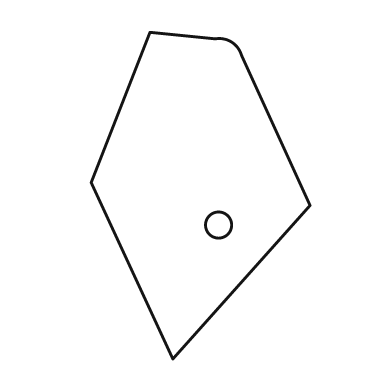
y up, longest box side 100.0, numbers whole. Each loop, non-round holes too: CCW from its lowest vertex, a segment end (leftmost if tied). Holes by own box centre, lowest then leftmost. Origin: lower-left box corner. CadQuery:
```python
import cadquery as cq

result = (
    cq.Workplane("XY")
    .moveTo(25.0, 0.0)
    .lineTo(67.0, 47.0)
    .lineTo(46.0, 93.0)
    .threePointArc((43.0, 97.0), (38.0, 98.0))
    .lineTo(18.0, 100.0)
    .lineTo(0.0, 54.0)
    .close()
    .moveTo(39.0, 41.0)
    .circle(4.0)
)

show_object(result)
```